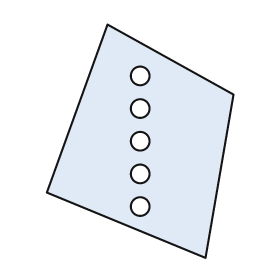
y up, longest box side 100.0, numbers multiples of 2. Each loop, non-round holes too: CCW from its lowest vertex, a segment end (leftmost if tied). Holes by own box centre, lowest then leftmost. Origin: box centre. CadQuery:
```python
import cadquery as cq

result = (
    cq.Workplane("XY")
    .moveTo(28.0, -50.0)
    .lineTo(40.0, 20.0)
    .lineTo(-14.0, 50.0)
    .lineTo(-40.0, -22.0)
    .close()
    .moveTo(0.0, -28.0)
    .circle(4.0)
    .moveTo(0.0, -14.0)
    .circle(4.0)
    .moveTo(0.0, 0.0)
    .circle(4.0)
    .moveTo(0.0, 14.0)
    .circle(4.0)
    .moveTo(0.0, 28.0)
    .circle(4.0)
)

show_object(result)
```